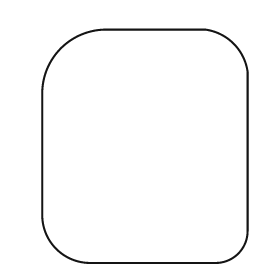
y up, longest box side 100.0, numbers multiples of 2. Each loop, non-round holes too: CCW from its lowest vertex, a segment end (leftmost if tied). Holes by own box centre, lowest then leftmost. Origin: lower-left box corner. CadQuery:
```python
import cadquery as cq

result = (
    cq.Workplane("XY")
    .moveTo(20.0, 0.0)
    .lineTo(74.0, 0.0)
    .threePointArc((84.0, 4.0), (88.0, 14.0))
    .lineTo(88.0, 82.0)
    .threePointArc((82.0, 94.0), (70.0, 100.0))
    .lineTo(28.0, 100.0)
    .threePointArc((8.0, 92.0), (0.0, 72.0))
    .lineTo(0.0, 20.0)
    .threePointArc((6.0, 6.0), (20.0, 0.0))
    .close()
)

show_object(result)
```